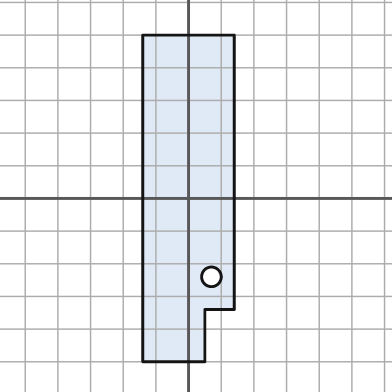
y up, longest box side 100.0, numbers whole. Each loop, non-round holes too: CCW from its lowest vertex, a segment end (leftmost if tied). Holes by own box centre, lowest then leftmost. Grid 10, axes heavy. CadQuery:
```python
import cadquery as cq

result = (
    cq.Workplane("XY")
    .moveTo(-14.0, -50.0)
    .lineTo(5.0, -50.0)
    .lineTo(5.0, -34.0)
    .lineTo(14.0, -34.0)
    .lineTo(14.0, 50.0)
    .lineTo(-14.0, 50.0)
    .close()
    .moveTo(7.0, -24.0)
    .circle(3.0)
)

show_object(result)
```